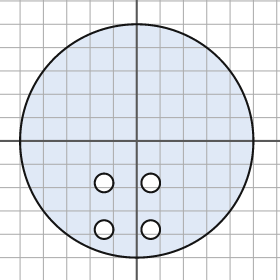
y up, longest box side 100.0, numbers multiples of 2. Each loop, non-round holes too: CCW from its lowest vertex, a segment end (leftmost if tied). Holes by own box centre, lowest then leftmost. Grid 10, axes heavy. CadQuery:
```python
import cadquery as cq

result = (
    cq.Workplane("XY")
    .moveTo(0.0, 0.0)
    .circle(50.0)
    .moveTo(-14.0, -38.0)
    .circle(4.0)
    .moveTo(6.0, -38.0)
    .circle(4.0)
    .moveTo(-14.0, -18.0)
    .circle(4.0)
    .moveTo(6.0, -18.0)
    .circle(4.0)
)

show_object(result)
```